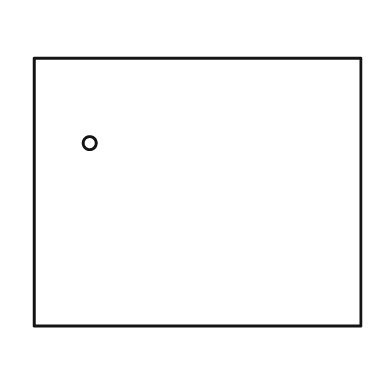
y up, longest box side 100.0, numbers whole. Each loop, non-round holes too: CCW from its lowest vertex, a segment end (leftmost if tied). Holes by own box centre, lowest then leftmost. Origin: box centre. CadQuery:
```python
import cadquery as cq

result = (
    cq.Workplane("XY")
    .moveTo(-50.0, -41.0)
    .lineTo(50.0, -41.0)
    .lineTo(50.0, 41.0)
    .lineTo(-50.0, 41.0)
    .close()
    .moveTo(-33.0, 15.0)
    .circle(2.0)
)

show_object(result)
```